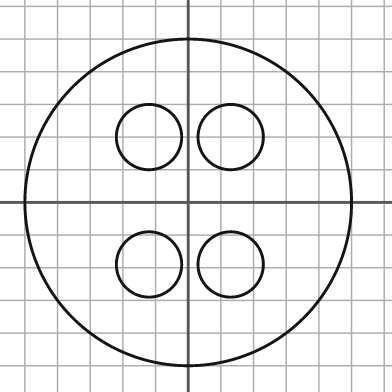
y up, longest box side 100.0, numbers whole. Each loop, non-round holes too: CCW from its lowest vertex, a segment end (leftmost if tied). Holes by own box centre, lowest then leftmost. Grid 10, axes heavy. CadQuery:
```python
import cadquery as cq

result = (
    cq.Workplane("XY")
    .moveTo(0.0, 0.0)
    .circle(50.0)
    .moveTo(-12.0, -19.0)
    .circle(10.0)
    .moveTo(13.0, -19.0)
    .circle(10.0)
    .moveTo(-12.0, 20.0)
    .circle(10.0)
    .moveTo(13.0, 20.0)
    .circle(10.0)
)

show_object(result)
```